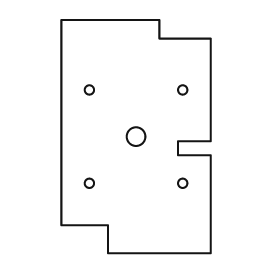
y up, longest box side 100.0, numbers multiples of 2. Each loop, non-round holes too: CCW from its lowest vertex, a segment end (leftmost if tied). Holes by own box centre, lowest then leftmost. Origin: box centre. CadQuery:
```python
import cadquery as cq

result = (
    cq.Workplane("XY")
    .moveTo(-12.0, -50.0)
    .lineTo(32.0, -50.0)
    .lineTo(32.0, -8.0)
    .lineTo(18.0, -8.0)
    .lineTo(18.0, -2.0)
    .lineTo(32.0, -2.0)
    .lineTo(32.0, 42.0)
    .lineTo(10.0, 42.0)
    .lineTo(10.0, 50.0)
    .lineTo(-32.0, 50.0)
    .lineTo(-32.0, -38.0)
    .lineTo(-12.0, -38.0)
    .close()
    .moveTo(-20.0, -20.0)
    .circle(2.0)
    .moveTo(20.0, -20.0)
    .circle(2.0)
    .moveTo(0.0, 0.0)
    .circle(4.0)
    .moveTo(-20.0, 20.0)
    .circle(2.0)
    .moveTo(20.0, 20.0)
    .circle(2.0)
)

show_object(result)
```